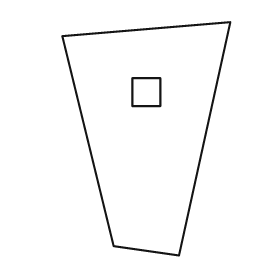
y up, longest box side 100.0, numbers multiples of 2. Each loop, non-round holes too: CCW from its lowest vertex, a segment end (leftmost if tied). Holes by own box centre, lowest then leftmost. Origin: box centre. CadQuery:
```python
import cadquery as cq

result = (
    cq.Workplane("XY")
    .moveTo(14.0, -50.0)
    .lineTo(36.0, 50.0)
    .lineTo(-36.0, 44.0)
    .lineTo(-14.0, -46.0)
    .close()
    .moveTo(-6.0, 14.0)
    .lineTo(6.0, 14.0)
    .lineTo(6.0, 26.0)
    .lineTo(-6.0, 26.0)
    .close()
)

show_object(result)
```